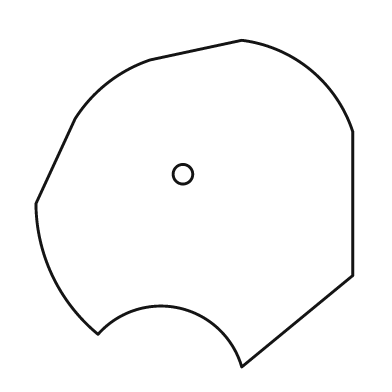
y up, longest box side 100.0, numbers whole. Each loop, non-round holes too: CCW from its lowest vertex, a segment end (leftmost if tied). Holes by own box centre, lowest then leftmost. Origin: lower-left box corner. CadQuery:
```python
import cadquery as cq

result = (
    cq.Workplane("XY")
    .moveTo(63.0, 0.0)
    .lineTo(97.0, 28.0)
    .lineTo(97.0, 72.0)
    .threePointArc((84.0, 91.0), (63.0, 100.0))
    .lineTo(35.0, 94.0)
    .threePointArc((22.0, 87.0), (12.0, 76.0))
    .lineTo(0.0, 50.0)
    .threePointArc((5.0, 28.0), (19.0, 10.0))
    .threePointArc((44.0, 18.0), (63.0, 0.0))
    .close()
    .moveTo(45.0, 59.0)
    .circle(3.0)
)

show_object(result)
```